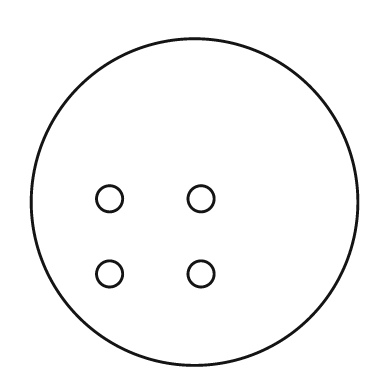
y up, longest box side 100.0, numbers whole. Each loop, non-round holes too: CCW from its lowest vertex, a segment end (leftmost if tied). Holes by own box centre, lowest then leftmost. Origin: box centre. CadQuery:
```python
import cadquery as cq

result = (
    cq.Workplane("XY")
    .moveTo(0.0, 0.0)
    .circle(50.0)
    .moveTo(-26.0, -22.0)
    .circle(4.0)
    .moveTo(2.0, -22.0)
    .circle(4.0)
    .moveTo(-26.0, 1.0)
    .circle(4.0)
    .moveTo(2.0, 1.0)
    .circle(4.0)
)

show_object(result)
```